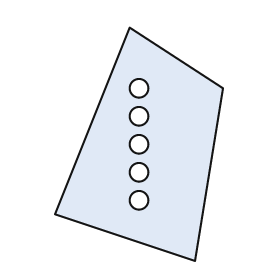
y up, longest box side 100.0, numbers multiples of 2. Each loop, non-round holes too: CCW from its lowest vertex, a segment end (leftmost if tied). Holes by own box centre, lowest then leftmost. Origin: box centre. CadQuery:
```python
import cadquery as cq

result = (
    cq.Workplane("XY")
    .moveTo(24.0, -50.0)
    .lineTo(36.0, 24.0)
    .lineTo(-4.0, 50.0)
    .lineTo(-36.0, -30.0)
    .close()
    .moveTo(0.0, -24.0)
    .circle(4.0)
    .moveTo(0.0, -12.0)
    .circle(4.0)
    .moveTo(0.0, 0.0)
    .circle(4.0)
    .moveTo(0.0, 12.0)
    .circle(4.0)
    .moveTo(0.0, 24.0)
    .circle(4.0)
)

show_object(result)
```